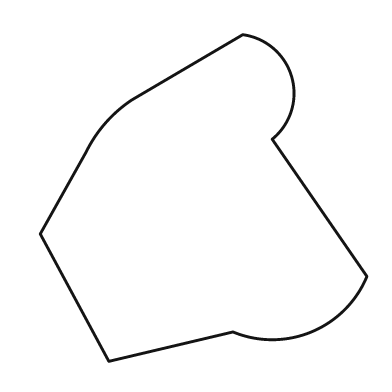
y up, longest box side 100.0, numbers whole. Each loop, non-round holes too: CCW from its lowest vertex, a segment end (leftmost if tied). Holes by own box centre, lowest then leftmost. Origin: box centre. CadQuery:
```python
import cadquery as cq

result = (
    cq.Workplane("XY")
    .moveTo(-29.0, -50.0)
    .lineTo(9.0, -41.0)
    .threePointArc((33.0, -41.0), (50.0, -24.0))
    .lineTo(21.0, 18.0)
    .threePointArc((27.0, 37.0), (12.0, 50.0))
    .lineTo(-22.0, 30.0)
    .threePointArc((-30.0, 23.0), (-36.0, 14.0))
    .lineTo(-50.0, -11.0)
    .close()
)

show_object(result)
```